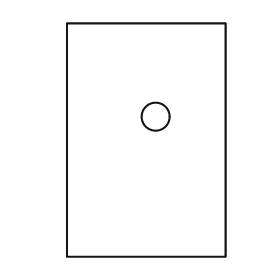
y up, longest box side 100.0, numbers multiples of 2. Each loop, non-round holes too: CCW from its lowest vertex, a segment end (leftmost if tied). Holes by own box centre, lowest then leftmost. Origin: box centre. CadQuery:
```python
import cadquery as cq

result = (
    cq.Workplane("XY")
    .moveTo(-34.0, -50.0)
    .lineTo(34.0, -50.0)
    .lineTo(34.0, 50.0)
    .lineTo(-34.0, 50.0)
    .close()
    .moveTo(4.0, 10.0)
    .circle(6.0)
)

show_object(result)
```